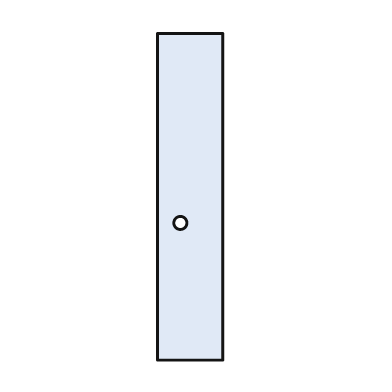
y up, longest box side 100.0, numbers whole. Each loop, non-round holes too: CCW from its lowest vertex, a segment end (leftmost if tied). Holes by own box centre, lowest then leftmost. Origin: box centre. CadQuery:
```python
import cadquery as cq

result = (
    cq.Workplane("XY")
    .moveTo(-10.0, -50.0)
    .lineTo(10.0, -50.0)
    .lineTo(10.0, 50.0)
    .lineTo(-10.0, 50.0)
    .close()
    .moveTo(-3.0, -8.0)
    .circle(2.0)
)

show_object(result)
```